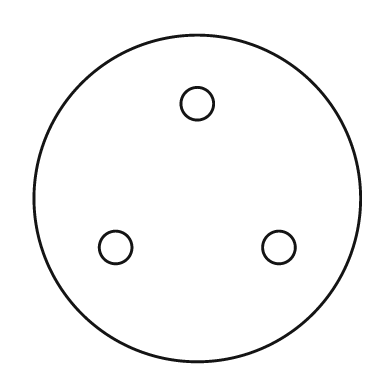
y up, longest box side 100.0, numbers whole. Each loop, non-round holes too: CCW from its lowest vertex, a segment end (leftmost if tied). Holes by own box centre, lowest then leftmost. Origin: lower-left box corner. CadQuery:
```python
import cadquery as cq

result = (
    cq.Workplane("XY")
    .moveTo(50.0, 50.0)
    .circle(50.0)
    .moveTo(25.0, 35.0)
    .circle(5.0)
    .moveTo(75.0, 35.0)
    .circle(5.0)
    .moveTo(50.0, 79.0)
    .circle(5.0)
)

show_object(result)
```